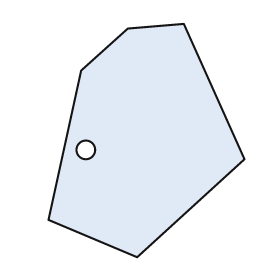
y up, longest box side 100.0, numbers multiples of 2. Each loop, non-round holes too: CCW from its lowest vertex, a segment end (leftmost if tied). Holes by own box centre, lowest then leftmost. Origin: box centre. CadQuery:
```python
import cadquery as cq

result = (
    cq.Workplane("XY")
    .moveTo(-4.0, -50.0)
    .lineTo(42.0, -8.0)
    .lineTo(16.0, 50.0)
    .lineTo(-8.0, 48.0)
    .lineTo(-28.0, 30.0)
    .lineTo(-42.0, -34.0)
    .close()
    .moveTo(-26.0, -4.0)
    .circle(4.0)
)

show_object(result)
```